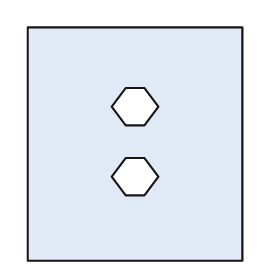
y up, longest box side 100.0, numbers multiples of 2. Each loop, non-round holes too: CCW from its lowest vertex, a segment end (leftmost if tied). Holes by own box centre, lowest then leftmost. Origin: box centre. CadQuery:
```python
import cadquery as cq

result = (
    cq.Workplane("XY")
    .moveTo(-46.0, -50.0)
    .lineTo(46.0, -50.0)
    .lineTo(46.0, 50.0)
    .lineTo(-46.0, 50.0)
    .close()
    .moveTo(-4.0, -22.0)
    .lineTo(4.0, -22.0)
    .lineTo(10.0, -14.0)
    .lineTo(4.0, -6.0)
    .lineTo(-4.0, -6.0)
    .lineTo(-10.0, -14.0)
    .close()
    .moveTo(-4.0, 8.0)
    .lineTo(4.0, 8.0)
    .lineTo(10.0, 16.0)
    .lineTo(4.0, 24.0)
    .lineTo(-4.0, 24.0)
    .lineTo(-10.0, 16.0)
    .close()
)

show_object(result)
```